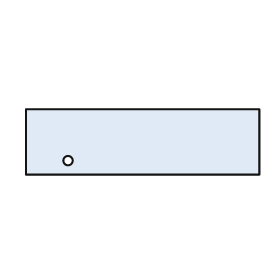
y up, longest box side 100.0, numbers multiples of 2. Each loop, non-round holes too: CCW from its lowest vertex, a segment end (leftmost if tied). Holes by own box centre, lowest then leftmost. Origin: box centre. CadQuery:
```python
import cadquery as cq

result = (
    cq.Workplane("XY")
    .moveTo(-50.0, -14.0)
    .lineTo(50.0, -14.0)
    .lineTo(50.0, 14.0)
    .lineTo(-50.0, 14.0)
    .close()
    .moveTo(-32.0, -8.0)
    .circle(2.0)
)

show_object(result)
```